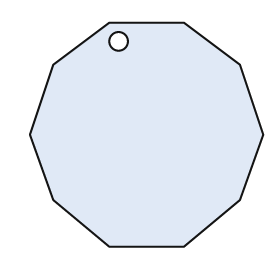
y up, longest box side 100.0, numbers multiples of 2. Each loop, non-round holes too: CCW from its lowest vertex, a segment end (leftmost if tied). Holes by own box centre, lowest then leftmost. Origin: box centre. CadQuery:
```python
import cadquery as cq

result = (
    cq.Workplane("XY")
    .moveTo(-16.0, -48.0)
    .lineTo(16.0, -48.0)
    .lineTo(40.0, -28.0)
    .lineTo(50.0, 0.0)
    .lineTo(40.0, 30.0)
    .lineTo(16.0, 48.0)
    .lineTo(-16.0, 48.0)
    .lineTo(-40.0, 30.0)
    .lineTo(-50.0, 0.0)
    .lineTo(-40.0, -28.0)
    .close()
    .moveTo(-12.0, 40.0)
    .circle(4.0)
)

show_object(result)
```